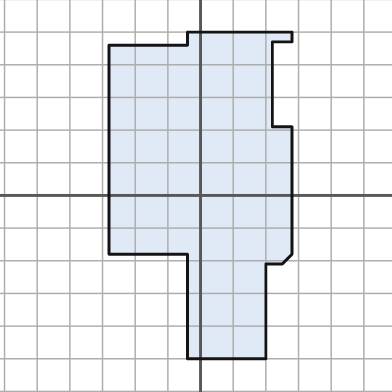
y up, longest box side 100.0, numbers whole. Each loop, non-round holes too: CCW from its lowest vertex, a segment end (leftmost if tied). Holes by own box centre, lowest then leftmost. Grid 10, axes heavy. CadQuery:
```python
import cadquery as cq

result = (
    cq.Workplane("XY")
    .moveTo(-4.0, -50.0)
    .lineTo(20.0, -50.0)
    .lineTo(20.0, -21.0)
    .lineTo(25.0, -21.0)
    .lineTo(28.0, -18.0)
    .lineTo(28.0, 21.0)
    .lineTo(22.0, 21.0)
    .lineTo(22.0, 47.0)
    .lineTo(28.0, 47.0)
    .lineTo(28.0, 50.0)
    .lineTo(-4.0, 50.0)
    .lineTo(-4.0, 46.0)
    .lineTo(-28.0, 46.0)
    .lineTo(-28.0, -18.0)
    .lineTo(-4.0, -18.0)
    .close()
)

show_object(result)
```